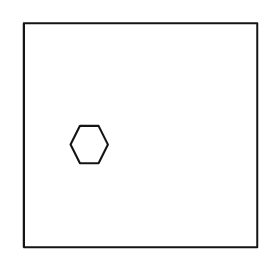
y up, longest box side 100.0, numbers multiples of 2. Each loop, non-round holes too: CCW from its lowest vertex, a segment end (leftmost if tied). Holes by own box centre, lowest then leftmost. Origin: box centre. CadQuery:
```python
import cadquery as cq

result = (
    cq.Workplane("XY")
    .moveTo(-50.0, -48.0)
    .lineTo(50.0, -48.0)
    .lineTo(50.0, 48.0)
    .lineTo(-50.0, 48.0)
    .close()
    .moveTo(-26.0, -12.0)
    .lineTo(-18.0, -12.0)
    .lineTo(-14.0, -4.0)
    .lineTo(-18.0, 4.0)
    .lineTo(-26.0, 4.0)
    .lineTo(-30.0, -4.0)
    .close()
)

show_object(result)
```